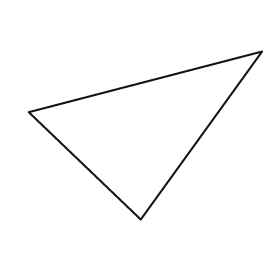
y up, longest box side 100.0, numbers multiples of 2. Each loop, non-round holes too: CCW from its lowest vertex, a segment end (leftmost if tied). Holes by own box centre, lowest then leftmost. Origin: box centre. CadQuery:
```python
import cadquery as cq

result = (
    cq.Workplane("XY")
    .moveTo(-2.0, -36.0)
    .lineTo(50.0, 36.0)
    .lineTo(-50.0, 10.0)
    .close()
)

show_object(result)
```